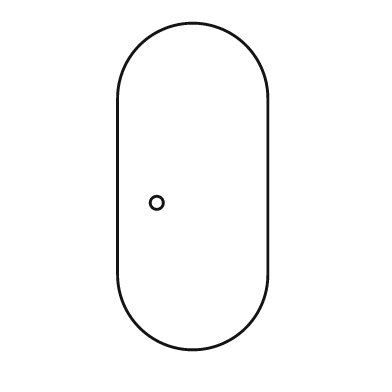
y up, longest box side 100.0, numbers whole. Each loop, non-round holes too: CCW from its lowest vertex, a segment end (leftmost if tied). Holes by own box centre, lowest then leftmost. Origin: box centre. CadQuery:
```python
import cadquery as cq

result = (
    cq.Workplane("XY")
    .moveTo(-23.0, -27.0)
    .threePointArc((0.0, -50.0), (23.0, -27.0))
    .lineTo(23.0, 27.0)
    .threePointArc((0.0, 50.0), (-23.0, 27.0))
    .close()
    .moveTo(-11.0, -5.0)
    .circle(2.0)
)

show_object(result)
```